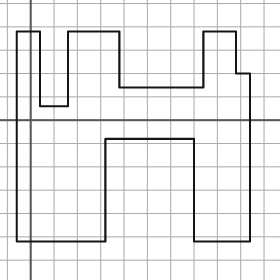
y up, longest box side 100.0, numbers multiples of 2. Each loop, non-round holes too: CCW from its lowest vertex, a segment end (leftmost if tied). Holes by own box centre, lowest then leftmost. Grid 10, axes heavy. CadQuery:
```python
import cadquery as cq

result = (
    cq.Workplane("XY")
    .moveTo(-6.0, -52.0)
    .lineTo(32.0, -52.0)
    .lineTo(32.0, -8.0)
    .lineTo(70.0, -8.0)
    .lineTo(70.0, -52.0)
    .lineTo(94.0, -52.0)
    .lineTo(94.0, 20.0)
    .lineTo(88.0, 20.0)
    .lineTo(88.0, 38.0)
    .lineTo(74.0, 38.0)
    .lineTo(74.0, 14.0)
    .lineTo(38.0, 14.0)
    .lineTo(38.0, 38.0)
    .lineTo(16.0, 38.0)
    .lineTo(16.0, 6.0)
    .lineTo(4.0, 6.0)
    .lineTo(4.0, 38.0)
    .lineTo(-6.0, 38.0)
    .close()
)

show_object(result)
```